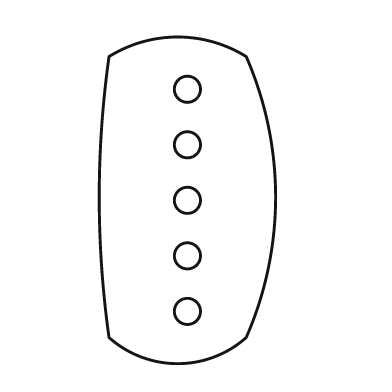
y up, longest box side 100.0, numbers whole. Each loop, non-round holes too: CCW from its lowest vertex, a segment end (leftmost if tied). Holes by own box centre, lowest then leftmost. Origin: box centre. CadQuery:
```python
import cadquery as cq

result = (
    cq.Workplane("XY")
    .moveTo(-24.0, -42.0)
    .threePointArc((-3.0, -50.0), (18.0, -42.0))
    .threePointArc((27.0, 1.0), (18.0, 44.0))
    .threePointArc((-3.0, 50.0), (-24.0, 44.0))
    .threePointArc((-27.0, 1.0), (-24.0, -42.0))
    .close()
    .moveTo(0.0, -34.0)
    .circle(4.0)
    .moveTo(0.0, -17.0)
    .circle(4.0)
    .moveTo(0.0, 0.0)
    .circle(4.0)
    .moveTo(0.0, 17.0)
    .circle(4.0)
    .moveTo(0.0, 34.0)
    .circle(4.0)
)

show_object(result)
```